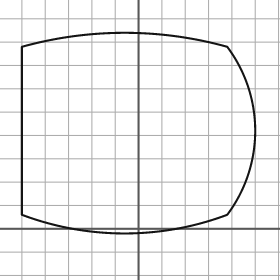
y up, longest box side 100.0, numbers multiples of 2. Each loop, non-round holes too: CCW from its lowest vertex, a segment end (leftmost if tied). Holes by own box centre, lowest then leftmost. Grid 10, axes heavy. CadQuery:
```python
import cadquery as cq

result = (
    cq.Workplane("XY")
    .moveTo(-50.0, 6.0)
    .threePointArc((-6.0, -2.0), (38.0, 6.0))
    .threePointArc((50.0, 42.0), (38.0, 78.0))
    .threePointArc((-6.0, 84.0), (-50.0, 78.0))
    .close()
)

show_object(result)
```